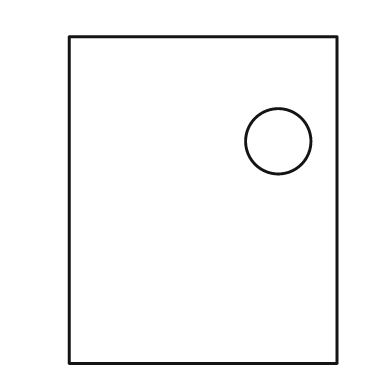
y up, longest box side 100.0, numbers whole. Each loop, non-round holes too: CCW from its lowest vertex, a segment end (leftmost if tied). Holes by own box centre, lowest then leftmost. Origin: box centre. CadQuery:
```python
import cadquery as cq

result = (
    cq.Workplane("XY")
    .moveTo(-41.0, -50.0)
    .lineTo(41.0, -50.0)
    .lineTo(41.0, 50.0)
    .lineTo(-41.0, 50.0)
    .close()
    .moveTo(23.0, 18.0)
    .circle(10.0)
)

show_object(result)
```